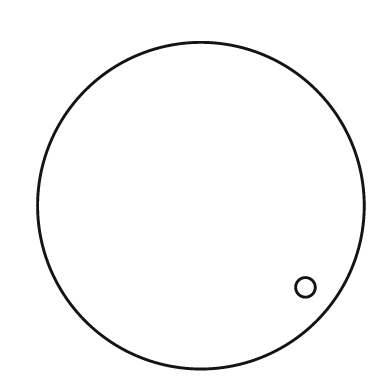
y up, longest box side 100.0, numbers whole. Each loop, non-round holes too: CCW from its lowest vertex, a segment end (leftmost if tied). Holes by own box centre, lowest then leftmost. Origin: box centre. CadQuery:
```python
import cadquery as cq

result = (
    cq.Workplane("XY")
    .moveTo(0.0, 0.0)
    .circle(50.0)
    .moveTo(32.0, -25.0)
    .circle(3.0)
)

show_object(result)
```